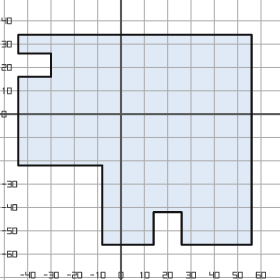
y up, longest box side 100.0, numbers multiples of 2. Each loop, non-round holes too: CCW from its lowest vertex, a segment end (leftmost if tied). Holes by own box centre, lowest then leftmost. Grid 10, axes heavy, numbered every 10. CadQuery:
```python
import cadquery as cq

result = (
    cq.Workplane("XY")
    .moveTo(-8.0, -56.0)
    .lineTo(14.0, -56.0)
    .lineTo(14.0, -42.0)
    .lineTo(26.0, -42.0)
    .lineTo(26.0, -56.0)
    .lineTo(56.0, -56.0)
    .lineTo(56.0, 34.0)
    .lineTo(-44.0, 34.0)
    .lineTo(-44.0, 26.0)
    .lineTo(-30.0, 26.0)
    .lineTo(-30.0, 16.0)
    .lineTo(-44.0, 16.0)
    .lineTo(-44.0, -22.0)
    .lineTo(-8.0, -22.0)
    .close()
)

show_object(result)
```